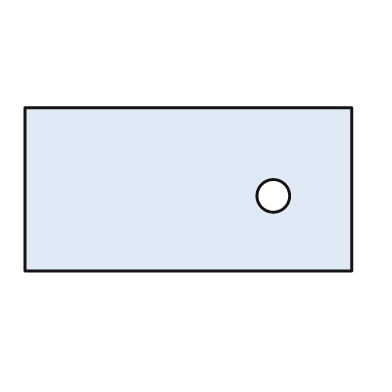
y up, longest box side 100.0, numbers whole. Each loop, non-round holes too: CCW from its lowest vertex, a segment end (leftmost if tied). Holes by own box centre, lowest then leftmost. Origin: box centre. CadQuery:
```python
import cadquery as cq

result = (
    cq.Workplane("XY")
    .moveTo(-50.0, -25.0)
    .lineTo(50.0, -25.0)
    .lineTo(50.0, 25.0)
    .lineTo(-50.0, 25.0)
    .close()
    .moveTo(26.0, -2.0)
    .circle(5.0)
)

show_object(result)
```